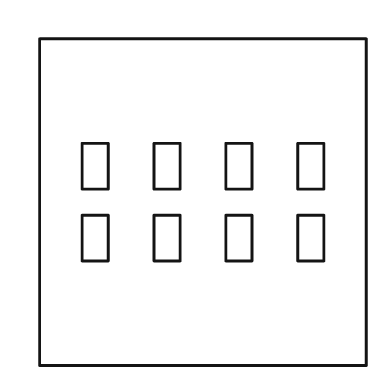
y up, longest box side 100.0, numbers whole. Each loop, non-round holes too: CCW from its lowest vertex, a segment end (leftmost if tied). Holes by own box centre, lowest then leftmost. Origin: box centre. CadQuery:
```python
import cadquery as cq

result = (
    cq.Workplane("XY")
    .moveTo(-50.0, -50.0)
    .lineTo(50.0, -50.0)
    .lineTo(50.0, 50.0)
    .lineTo(-50.0, 50.0)
    .close()
    .moveTo(-37.0, -18.0)
    .lineTo(-29.0, -18.0)
    .lineTo(-29.0, -4.0)
    .lineTo(-37.0, -4.0)
    .close()
    .moveTo(-15.0, -18.0)
    .lineTo(-7.0, -18.0)
    .lineTo(-7.0, -4.0)
    .lineTo(-15.0, -4.0)
    .close()
    .moveTo(7.0, -18.0)
    .lineTo(15.0, -18.0)
    .lineTo(15.0, -4.0)
    .lineTo(7.0, -4.0)
    .close()
    .moveTo(29.0, -18.0)
    .lineTo(37.0, -18.0)
    .lineTo(37.0, -4.0)
    .lineTo(29.0, -4.0)
    .close()
    .moveTo(-37.0, 4.0)
    .lineTo(-29.0, 4.0)
    .lineTo(-29.0, 18.0)
    .lineTo(-37.0, 18.0)
    .close()
    .moveTo(-15.0, 4.0)
    .lineTo(-7.0, 4.0)
    .lineTo(-7.0, 18.0)
    .lineTo(-15.0, 18.0)
    .close()
    .moveTo(7.0, 4.0)
    .lineTo(15.0, 4.0)
    .lineTo(15.0, 18.0)
    .lineTo(7.0, 18.0)
    .close()
    .moveTo(29.0, 4.0)
    .lineTo(37.0, 4.0)
    .lineTo(37.0, 18.0)
    .lineTo(29.0, 18.0)
    .close()
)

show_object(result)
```